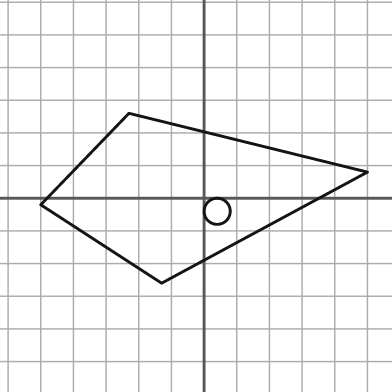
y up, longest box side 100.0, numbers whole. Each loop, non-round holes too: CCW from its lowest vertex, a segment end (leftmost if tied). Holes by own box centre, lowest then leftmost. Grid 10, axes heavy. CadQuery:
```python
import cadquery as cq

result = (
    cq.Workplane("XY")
    .moveTo(-13.0, -26.0)
    .lineTo(50.0, 8.0)
    .lineTo(-23.0, 26.0)
    .lineTo(-50.0, -2.0)
    .close()
    .moveTo(4.0, -4.0)
    .circle(4.0)
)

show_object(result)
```